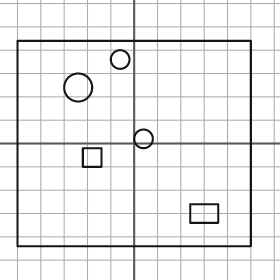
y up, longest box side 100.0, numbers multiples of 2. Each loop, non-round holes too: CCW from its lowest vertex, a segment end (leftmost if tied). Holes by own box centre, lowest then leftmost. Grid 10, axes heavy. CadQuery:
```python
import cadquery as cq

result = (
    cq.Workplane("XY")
    .moveTo(-50.0, -44.0)
    .lineTo(50.0, -44.0)
    .lineTo(50.0, 44.0)
    .lineTo(-50.0, 44.0)
    .close()
    .moveTo(24.0, -34.0)
    .lineTo(36.0, -34.0)
    .lineTo(36.0, -26.0)
    .lineTo(24.0, -26.0)
    .close()
    .moveTo(-22.0, -10.0)
    .lineTo(-14.0, -10.0)
    .lineTo(-14.0, -2.0)
    .lineTo(-22.0, -2.0)
    .close()
    .moveTo(4.0, 2.0)
    .circle(4.0)
    .moveTo(-24.0, 24.0)
    .circle(6.0)
    .moveTo(-6.0, 36.0)
    .circle(4.0)
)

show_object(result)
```